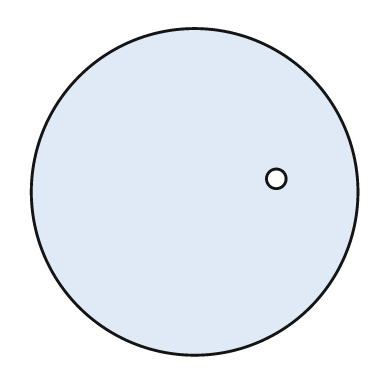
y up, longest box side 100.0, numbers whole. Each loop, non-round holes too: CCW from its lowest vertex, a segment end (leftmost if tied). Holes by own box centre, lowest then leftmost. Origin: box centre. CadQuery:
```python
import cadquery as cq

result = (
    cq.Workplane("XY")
    .moveTo(0.0, 0.0)
    .circle(50.0)
    .moveTo(25.0, 4.0)
    .circle(3.0)
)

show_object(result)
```